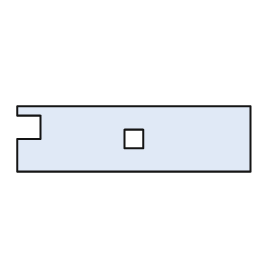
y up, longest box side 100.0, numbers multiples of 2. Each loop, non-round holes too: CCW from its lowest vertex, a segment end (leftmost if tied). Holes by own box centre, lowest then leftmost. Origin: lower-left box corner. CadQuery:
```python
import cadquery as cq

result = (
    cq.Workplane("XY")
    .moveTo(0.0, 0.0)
    .lineTo(100.0, 0.0)
    .lineTo(100.0, 28.0)
    .lineTo(0.0, 28.0)
    .lineTo(0.0, 24.0)
    .lineTo(10.0, 24.0)
    .lineTo(10.0, 14.0)
    .lineTo(0.0, 14.0)
    .close()
    .moveTo(46.0, 10.0)
    .lineTo(54.0, 10.0)
    .lineTo(54.0, 18.0)
    .lineTo(46.0, 18.0)
    .close()
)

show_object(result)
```